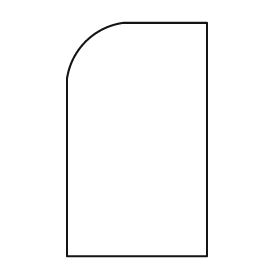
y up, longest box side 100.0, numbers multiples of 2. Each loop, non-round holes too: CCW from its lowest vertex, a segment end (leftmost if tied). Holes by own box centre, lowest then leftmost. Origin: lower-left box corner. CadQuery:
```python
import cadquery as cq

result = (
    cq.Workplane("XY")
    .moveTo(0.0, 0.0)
    .lineTo(60.0, 0.0)
    .lineTo(60.0, 100.0)
    .lineTo(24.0, 100.0)
    .threePointArc((8.0, 92.0), (0.0, 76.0))
    .close()
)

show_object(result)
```